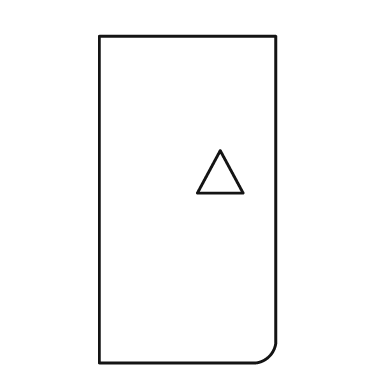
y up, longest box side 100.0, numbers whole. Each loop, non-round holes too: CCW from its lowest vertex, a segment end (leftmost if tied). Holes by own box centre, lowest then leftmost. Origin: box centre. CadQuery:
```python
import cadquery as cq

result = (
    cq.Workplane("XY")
    .moveTo(-27.0, -50.0)
    .lineTo(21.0, -50.0)
    .threePointArc((25.0, -48.0), (27.0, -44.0))
    .lineTo(27.0, 50.0)
    .lineTo(-27.0, 50.0)
    .close()
    .moveTo(3.0, 2.0)
    .lineTo(17.0, 2.0)
    .lineTo(10.0, 15.0)
    .close()
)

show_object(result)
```